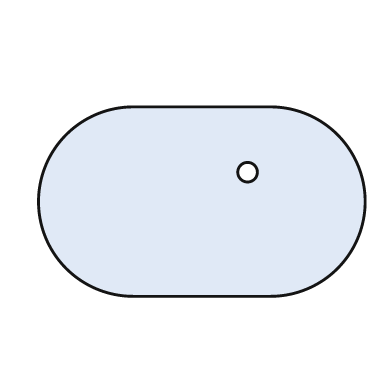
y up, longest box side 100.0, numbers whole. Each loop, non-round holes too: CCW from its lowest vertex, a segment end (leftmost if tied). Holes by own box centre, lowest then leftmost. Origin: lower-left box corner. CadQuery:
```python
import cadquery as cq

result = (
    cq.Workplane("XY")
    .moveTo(29.0, 0.0)
    .lineTo(71.0, 0.0)
    .threePointArc((100.0, 29.0), (71.0, 58.0))
    .lineTo(29.0, 58.0)
    .threePointArc((0.0, 29.0), (29.0, 0.0))
    .close()
    .moveTo(64.0, 38.0)
    .circle(3.0)
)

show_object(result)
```